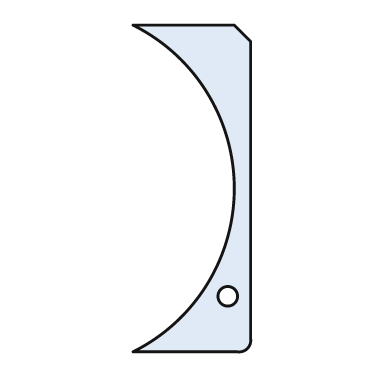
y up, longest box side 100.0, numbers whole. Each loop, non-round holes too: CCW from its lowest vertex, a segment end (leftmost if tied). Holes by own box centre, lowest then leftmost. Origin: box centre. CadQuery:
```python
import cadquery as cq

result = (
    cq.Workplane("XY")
    .moveTo(-18.0, -50.0)
    .lineTo(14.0, -50.0)
    .threePointArc((17.0, -49.0), (18.0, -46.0))
    .lineTo(18.0, 45.0)
    .lineTo(13.0, 50.0)
    .lineTo(-18.0, 50.0)
    .threePointArc((13.0, 0.0), (-18.0, -50.0))
    .close()
    .moveTo(11.0, -33.0)
    .circle(3.0)
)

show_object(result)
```